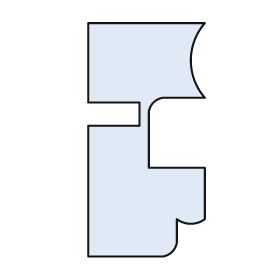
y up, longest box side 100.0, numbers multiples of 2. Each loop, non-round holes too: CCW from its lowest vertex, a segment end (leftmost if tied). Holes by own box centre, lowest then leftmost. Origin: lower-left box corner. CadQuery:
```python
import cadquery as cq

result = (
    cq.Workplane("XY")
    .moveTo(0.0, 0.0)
    .lineTo(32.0, 0.0)
    .threePointArc((36.0, 2.0), (38.0, 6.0))
    .lineTo(38.0, 16.0)
    .threePointArc((44.0, 14.0), (50.0, 16.0))
    .lineTo(50.0, 38.0)
    .lineTo(26.0, 38.0)
    .lineTo(26.0, 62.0)
    .threePointArc((28.0, 66.0), (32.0, 68.0))
    .lineTo(50.0, 68.0)
    .threePointArc((44.0, 84.0), (50.0, 100.0))
    .lineTo(0.0, 100.0)
    .lineTo(0.0, 66.0)
    .lineTo(22.0, 66.0)
    .lineTo(22.0, 56.0)
    .lineTo(0.0, 56.0)
    .close()
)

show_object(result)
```